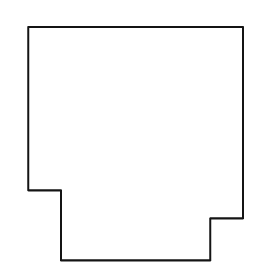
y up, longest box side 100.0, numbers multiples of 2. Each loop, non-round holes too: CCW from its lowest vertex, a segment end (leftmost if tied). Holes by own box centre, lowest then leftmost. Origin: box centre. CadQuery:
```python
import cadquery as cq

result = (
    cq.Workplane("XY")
    .moveTo(-32.0, -50.0)
    .lineTo(32.0, -50.0)
    .lineTo(32.0, -32.0)
    .lineTo(46.0, -32.0)
    .lineTo(46.0, 50.0)
    .lineTo(-46.0, 50.0)
    .lineTo(-46.0, -20.0)
    .lineTo(-32.0, -20.0)
    .close()
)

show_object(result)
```